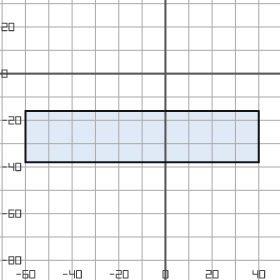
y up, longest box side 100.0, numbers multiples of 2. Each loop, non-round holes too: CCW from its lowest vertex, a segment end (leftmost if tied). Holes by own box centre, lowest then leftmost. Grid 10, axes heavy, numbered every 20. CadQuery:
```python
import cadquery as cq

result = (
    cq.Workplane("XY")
    .moveTo(-60.0, -38.0)
    .lineTo(40.0, -38.0)
    .lineTo(40.0, -16.0)
    .lineTo(-60.0, -16.0)
    .close()
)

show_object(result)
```